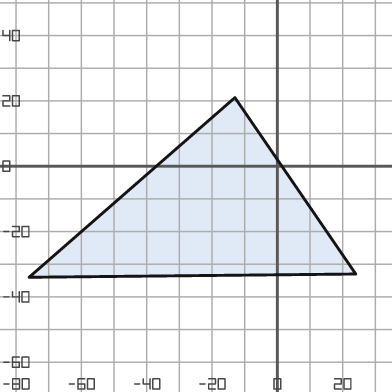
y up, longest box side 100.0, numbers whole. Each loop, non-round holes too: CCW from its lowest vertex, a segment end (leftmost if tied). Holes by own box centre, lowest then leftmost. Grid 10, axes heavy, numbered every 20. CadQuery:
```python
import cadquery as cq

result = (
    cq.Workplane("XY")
    .moveTo(-76.0, -34.0)
    .lineTo(24.0, -33.0)
    .lineTo(-13.0, 21.0)
    .close()
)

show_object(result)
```